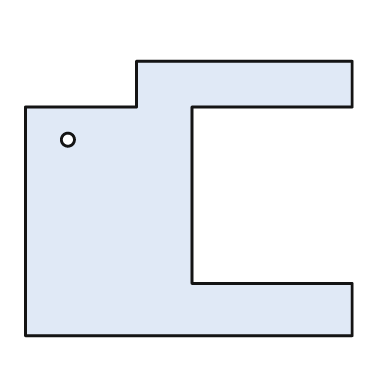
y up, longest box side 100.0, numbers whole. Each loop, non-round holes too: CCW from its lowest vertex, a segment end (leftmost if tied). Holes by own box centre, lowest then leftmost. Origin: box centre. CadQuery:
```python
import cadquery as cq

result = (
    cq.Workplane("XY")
    .moveTo(-50.0, -42.0)
    .lineTo(50.0, -42.0)
    .lineTo(50.0, -26.0)
    .lineTo(1.0, -26.0)
    .lineTo(1.0, 28.0)
    .lineTo(50.0, 28.0)
    .lineTo(50.0, 42.0)
    .lineTo(-16.0, 42.0)
    .lineTo(-16.0, 28.0)
    .lineTo(-50.0, 28.0)
    .close()
    .moveTo(-37.0, 18.0)
    .circle(2.0)
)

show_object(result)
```